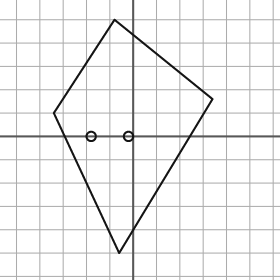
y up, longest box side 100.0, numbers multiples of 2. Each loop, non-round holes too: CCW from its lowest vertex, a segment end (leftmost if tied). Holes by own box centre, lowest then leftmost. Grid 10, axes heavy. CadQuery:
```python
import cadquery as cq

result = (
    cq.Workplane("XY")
    .moveTo(-6.0, -50.0)
    .lineTo(34.0, 16.0)
    .lineTo(-8.0, 50.0)
    .lineTo(-34.0, 10.0)
    .close()
    .moveTo(-18.0, 0.0)
    .circle(2.0)
    .moveTo(-2.0, 0.0)
    .circle(2.0)
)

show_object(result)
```